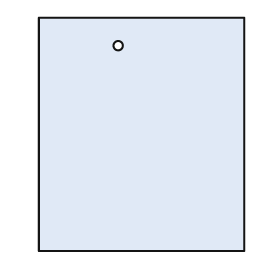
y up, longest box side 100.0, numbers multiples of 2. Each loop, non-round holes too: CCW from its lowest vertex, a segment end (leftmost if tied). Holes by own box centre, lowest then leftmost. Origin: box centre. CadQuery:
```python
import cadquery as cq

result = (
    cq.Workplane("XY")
    .moveTo(-44.0, -50.0)
    .lineTo(44.0, -50.0)
    .lineTo(44.0, 50.0)
    .lineTo(-44.0, 50.0)
    .close()
    .moveTo(-10.0, 38.0)
    .circle(2.0)
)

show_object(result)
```